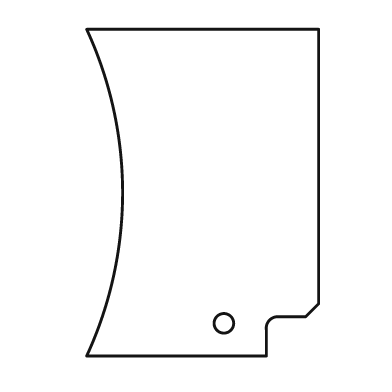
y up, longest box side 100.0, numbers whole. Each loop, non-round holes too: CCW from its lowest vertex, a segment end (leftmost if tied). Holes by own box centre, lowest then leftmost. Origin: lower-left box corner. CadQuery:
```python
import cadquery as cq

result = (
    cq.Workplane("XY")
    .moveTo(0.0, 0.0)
    .lineTo(55.0, 0.0)
    .lineTo(55.0, 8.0)
    .threePointArc((56.0, 11.0), (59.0, 12.0))
    .lineTo(67.0, 12.0)
    .lineTo(71.0, 16.0)
    .lineTo(71.0, 100.0)
    .lineTo(0.0, 100.0)
    .threePointArc((11.0, 50.0), (0.0, 0.0))
    .close()
    .moveTo(42.0, 10.0)
    .circle(3.0)
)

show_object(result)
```